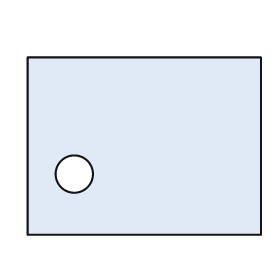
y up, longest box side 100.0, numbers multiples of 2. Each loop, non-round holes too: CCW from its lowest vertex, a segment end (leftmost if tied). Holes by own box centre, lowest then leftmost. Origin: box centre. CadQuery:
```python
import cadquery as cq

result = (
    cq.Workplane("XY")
    .moveTo(-50.0, -38.0)
    .lineTo(50.0, -38.0)
    .lineTo(50.0, 38.0)
    .lineTo(-50.0, 38.0)
    .close()
    .moveTo(-30.0, -12.0)
    .circle(8.0)
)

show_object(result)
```